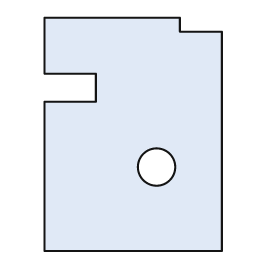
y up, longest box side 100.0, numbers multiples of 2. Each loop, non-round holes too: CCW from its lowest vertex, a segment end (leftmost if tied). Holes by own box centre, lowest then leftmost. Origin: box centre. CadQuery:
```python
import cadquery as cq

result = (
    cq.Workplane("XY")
    .moveTo(-38.0, -50.0)
    .lineTo(38.0, -50.0)
    .lineTo(38.0, 44.0)
    .lineTo(20.0, 44.0)
    .lineTo(20.0, 50.0)
    .lineTo(-38.0, 50.0)
    .lineTo(-38.0, 26.0)
    .lineTo(-16.0, 26.0)
    .lineTo(-16.0, 14.0)
    .lineTo(-38.0, 14.0)
    .close()
    .moveTo(10.0, -14.0)
    .circle(8.0)
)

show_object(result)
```